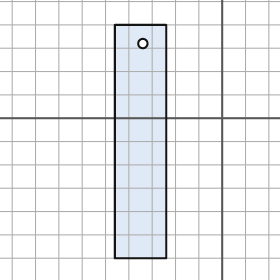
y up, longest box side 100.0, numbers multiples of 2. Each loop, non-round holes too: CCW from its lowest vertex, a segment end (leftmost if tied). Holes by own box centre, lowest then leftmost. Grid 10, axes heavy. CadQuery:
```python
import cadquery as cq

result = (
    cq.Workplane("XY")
    .moveTo(-46.0, -60.0)
    .lineTo(-24.0, -60.0)
    .lineTo(-24.0, 40.0)
    .lineTo(-46.0, 40.0)
    .close()
    .moveTo(-34.0, 32.0)
    .circle(2.0)
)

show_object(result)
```